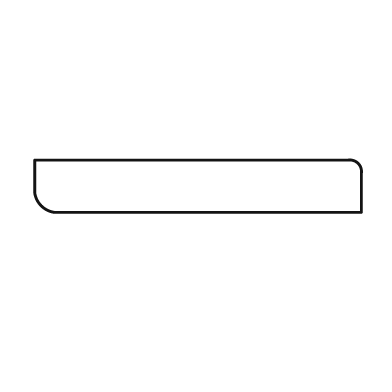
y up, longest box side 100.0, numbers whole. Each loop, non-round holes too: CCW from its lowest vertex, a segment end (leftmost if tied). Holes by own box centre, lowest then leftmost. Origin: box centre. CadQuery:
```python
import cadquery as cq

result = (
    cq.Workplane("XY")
    .moveTo(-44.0, -8.0)
    .lineTo(50.0, -8.0)
    .lineTo(50.0, 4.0)
    .threePointArc((49.0, 7.0), (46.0, 8.0))
    .lineTo(-50.0, 8.0)
    .lineTo(-50.0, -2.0)
    .threePointArc((-48.0, -6.0), (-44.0, -8.0))
    .close()
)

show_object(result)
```